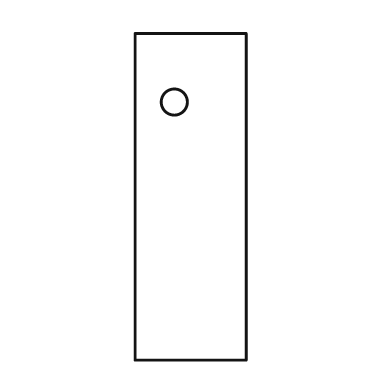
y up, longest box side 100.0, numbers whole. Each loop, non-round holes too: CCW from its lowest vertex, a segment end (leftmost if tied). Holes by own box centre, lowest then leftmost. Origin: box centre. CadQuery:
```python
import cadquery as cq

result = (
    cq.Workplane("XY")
    .moveTo(-17.0, -50.0)
    .lineTo(17.0, -50.0)
    .lineTo(17.0, 50.0)
    .lineTo(-17.0, 50.0)
    .close()
    .moveTo(-5.0, 29.0)
    .circle(4.0)
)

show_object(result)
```